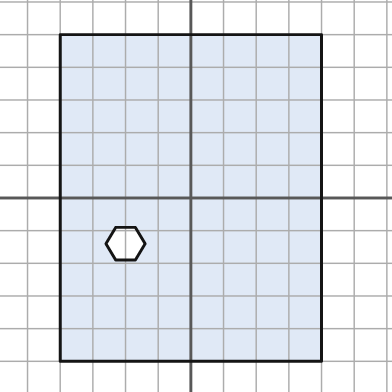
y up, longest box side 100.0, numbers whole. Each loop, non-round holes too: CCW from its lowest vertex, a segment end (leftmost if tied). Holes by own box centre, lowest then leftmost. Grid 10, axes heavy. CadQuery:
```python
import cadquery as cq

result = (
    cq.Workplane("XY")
    .moveTo(-40.0, -50.0)
    .lineTo(40.0, -50.0)
    .lineTo(40.0, 50.0)
    .lineTo(-40.0, 50.0)
    .close()
    .moveTo(-23.0, -19.0)
    .lineTo(-17.0, -19.0)
    .lineTo(-14.0, -14.0)
    .lineTo(-17.0, -9.0)
    .lineTo(-23.0, -9.0)
    .lineTo(-26.0, -14.0)
    .close()
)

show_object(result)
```